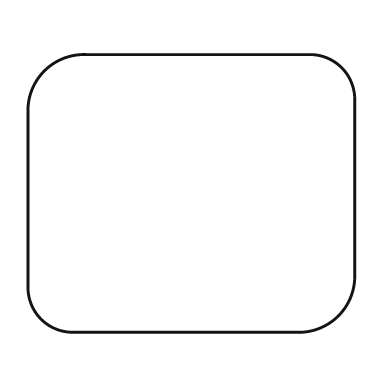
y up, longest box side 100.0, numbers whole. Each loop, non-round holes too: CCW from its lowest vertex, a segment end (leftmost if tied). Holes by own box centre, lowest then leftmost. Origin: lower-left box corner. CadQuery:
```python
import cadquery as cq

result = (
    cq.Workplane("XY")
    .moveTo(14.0, 0.0)
    .lineTo(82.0, 0.0)
    .threePointArc((95.0, 5.0), (100.0, 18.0))
    .lineTo(100.0, 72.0)
    .threePointArc((96.0, 81.0), (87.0, 85.0))
    .lineTo(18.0, 85.0)
    .threePointArc((5.0, 80.0), (0.0, 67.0))
    .lineTo(0.0, 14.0)
    .threePointArc((4.0, 4.0), (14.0, 0.0))
    .close()
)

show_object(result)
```